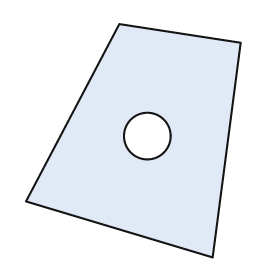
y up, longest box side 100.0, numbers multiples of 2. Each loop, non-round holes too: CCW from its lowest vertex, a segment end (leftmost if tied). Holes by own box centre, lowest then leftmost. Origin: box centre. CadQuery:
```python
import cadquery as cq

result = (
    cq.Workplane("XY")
    .moveTo(34.0, -50.0)
    .lineTo(46.0, 42.0)
    .lineTo(-6.0, 50.0)
    .lineTo(-46.0, -26.0)
    .close()
    .moveTo(6.0, 2.0)
    .circle(10.0)
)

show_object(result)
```